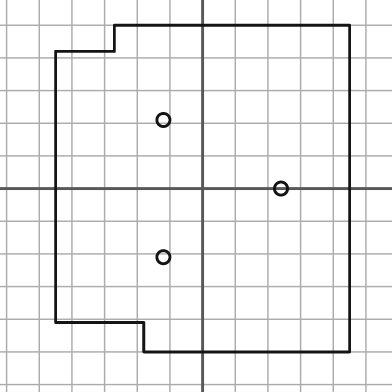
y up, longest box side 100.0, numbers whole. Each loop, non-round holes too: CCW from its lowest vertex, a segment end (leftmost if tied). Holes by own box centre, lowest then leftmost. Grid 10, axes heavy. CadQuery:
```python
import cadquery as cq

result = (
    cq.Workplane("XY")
    .moveTo(-18.0, -50.0)
    .lineTo(45.0, -50.0)
    .lineTo(45.0, 50.0)
    .lineTo(-27.0, 50.0)
    .lineTo(-27.0, 42.0)
    .lineTo(-45.0, 42.0)
    .lineTo(-45.0, -41.0)
    .lineTo(-18.0, -41.0)
    .close()
    .moveTo(-12.0, -21.0)
    .circle(2.0)
    .moveTo(24.0, 0.0)
    .circle(2.0)
    .moveTo(-12.0, 21.0)
    .circle(2.0)
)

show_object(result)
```